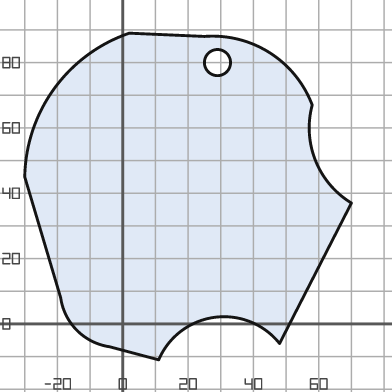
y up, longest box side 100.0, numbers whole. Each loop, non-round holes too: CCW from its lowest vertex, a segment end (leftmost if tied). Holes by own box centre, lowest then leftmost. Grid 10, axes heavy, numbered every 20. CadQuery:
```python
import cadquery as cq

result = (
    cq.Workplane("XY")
    .moveTo(11.0, -11.0)
    .threePointArc((28.0, 2.0), (48.0, -6.0))
    .lineTo(70.0, 37.0)
    .threePointArc((59.0, 50.0), (58.0, 67.0))
    .threePointArc((45.0, 83.0), (25.0, 88.0))
    .lineTo(2.0, 89.0)
    .threePointArc((-21.0, 72.0), (-30.0, 45.0))
    .lineTo(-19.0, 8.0)
    .threePointArc((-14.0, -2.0), (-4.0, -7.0))
    .close()
    .moveTo(29.0, 80.0)
    .circle(4.0)
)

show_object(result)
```